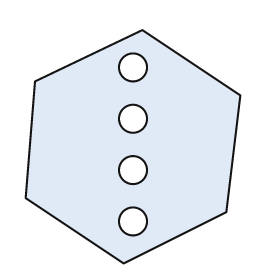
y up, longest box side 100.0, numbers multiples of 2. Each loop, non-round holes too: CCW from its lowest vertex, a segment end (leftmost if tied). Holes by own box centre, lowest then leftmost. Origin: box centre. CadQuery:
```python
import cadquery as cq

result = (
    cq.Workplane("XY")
    .moveTo(-4.0, -50.0)
    .lineTo(40.0, -28.0)
    .lineTo(46.0, 22.0)
    .lineTo(4.0, 50.0)
    .lineTo(-42.0, 28.0)
    .lineTo(-46.0, -22.0)
    .close()
    .moveTo(0.0, -32.0)
    .circle(6.0)
    .moveTo(0.0, -10.0)
    .circle(6.0)
    .moveTo(0.0, 12.0)
    .circle(6.0)
    .moveTo(0.0, 34.0)
    .circle(6.0)
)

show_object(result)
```